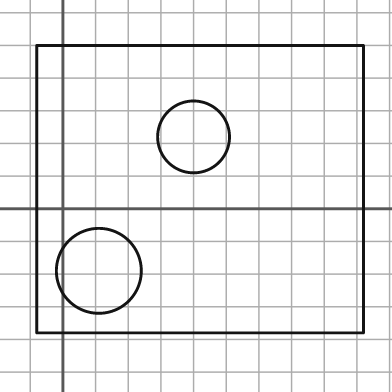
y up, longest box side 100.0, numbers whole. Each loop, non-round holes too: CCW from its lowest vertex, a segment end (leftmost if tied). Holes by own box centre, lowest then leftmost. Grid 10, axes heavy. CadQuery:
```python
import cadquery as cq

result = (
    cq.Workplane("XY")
    .moveTo(-8.0, -38.0)
    .lineTo(92.0, -38.0)
    .lineTo(92.0, 50.0)
    .lineTo(-8.0, 50.0)
    .close()
    .moveTo(11.0, -19.0)
    .circle(13.0)
    .moveTo(40.0, 22.0)
    .circle(11.0)
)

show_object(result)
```